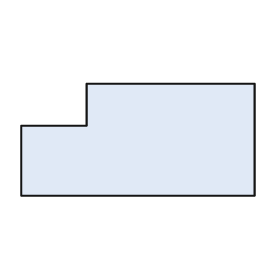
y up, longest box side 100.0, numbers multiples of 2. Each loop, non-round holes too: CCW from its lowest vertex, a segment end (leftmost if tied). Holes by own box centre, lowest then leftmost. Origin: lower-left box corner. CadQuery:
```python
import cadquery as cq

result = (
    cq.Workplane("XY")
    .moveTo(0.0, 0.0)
    .lineTo(100.0, 0.0)
    .lineTo(100.0, 48.0)
    .lineTo(28.0, 48.0)
    .lineTo(28.0, 30.0)
    .lineTo(0.0, 30.0)
    .close()
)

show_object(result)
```